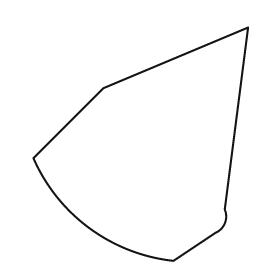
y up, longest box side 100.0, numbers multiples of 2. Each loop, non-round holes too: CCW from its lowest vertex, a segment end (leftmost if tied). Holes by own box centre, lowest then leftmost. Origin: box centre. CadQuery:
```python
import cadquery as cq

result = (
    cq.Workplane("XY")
    .moveTo(14.0, -50.0)
    .lineTo(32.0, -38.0)
    .threePointArc((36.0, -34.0), (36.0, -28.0))
    .lineTo(46.0, 50.0)
    .lineTo(-16.0, 24.0)
    .lineTo(-46.0, -6.0)
    .threePointArc((-22.0, -36.0), (14.0, -50.0))
    .close()
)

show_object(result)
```